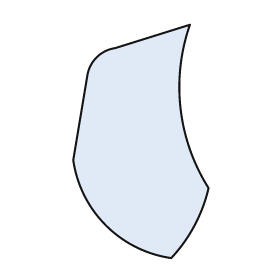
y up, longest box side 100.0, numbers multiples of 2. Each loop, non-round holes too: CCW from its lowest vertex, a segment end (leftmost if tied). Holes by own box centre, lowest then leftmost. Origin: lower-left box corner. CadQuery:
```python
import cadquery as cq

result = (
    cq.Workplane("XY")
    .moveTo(42.0, 0.0)
    .threePointArc((52.0, 14.0), (58.0, 30.0))
    .threePointArc((46.0, 64.0), (50.0, 100.0))
    .lineTo(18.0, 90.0)
    .threePointArc((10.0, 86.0), (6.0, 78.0))
    .lineTo(0.0, 42.0)
    .threePointArc((14.0, 14.0), (42.0, 0.0))
    .close()
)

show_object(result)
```